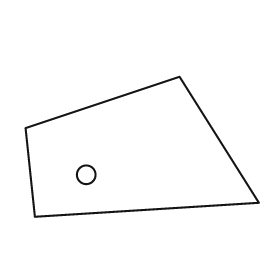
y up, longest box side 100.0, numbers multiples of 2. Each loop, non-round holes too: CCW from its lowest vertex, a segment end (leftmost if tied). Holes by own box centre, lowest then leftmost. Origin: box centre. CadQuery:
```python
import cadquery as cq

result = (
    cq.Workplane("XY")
    .moveTo(-46.0, -30.0)
    .lineTo(50.0, -24.0)
    .lineTo(16.0, 30.0)
    .lineTo(-50.0, 8.0)
    .close()
    .moveTo(-24.0, -12.0)
    .circle(4.0)
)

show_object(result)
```